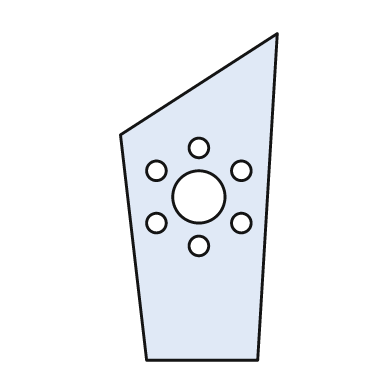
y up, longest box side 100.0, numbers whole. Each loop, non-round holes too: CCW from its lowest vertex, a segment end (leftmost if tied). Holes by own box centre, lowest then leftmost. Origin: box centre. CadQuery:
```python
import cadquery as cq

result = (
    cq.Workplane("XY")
    .moveTo(-16.0, -50.0)
    .lineTo(18.0, -50.0)
    .lineTo(24.0, 50.0)
    .lineTo(-24.0, 19.0)
    .close()
    .moveTo(0.0, -15.0)
    .circle(3.0)
    .moveTo(-13.0, -8.0)
    .circle(3.0)
    .moveTo(13.0, -8.0)
    .circle(3.0)
    .moveTo(0.0, 0.0)
    .circle(8.0)
    .moveTo(-13.0, 8.0)
    .circle(3.0)
    .moveTo(13.0, 8.0)
    .circle(3.0)
    .moveTo(0.0, 15.0)
    .circle(3.0)
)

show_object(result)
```